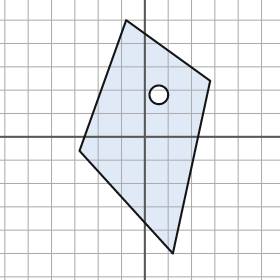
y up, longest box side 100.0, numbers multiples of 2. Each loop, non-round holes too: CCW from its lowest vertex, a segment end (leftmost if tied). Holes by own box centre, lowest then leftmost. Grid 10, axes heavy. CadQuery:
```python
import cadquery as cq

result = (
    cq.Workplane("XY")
    .moveTo(12.0, -50.0)
    .lineTo(28.0, 24.0)
    .lineTo(-8.0, 50.0)
    .lineTo(-28.0, -6.0)
    .close()
    .moveTo(6.0, 18.0)
    .circle(4.0)
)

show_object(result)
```